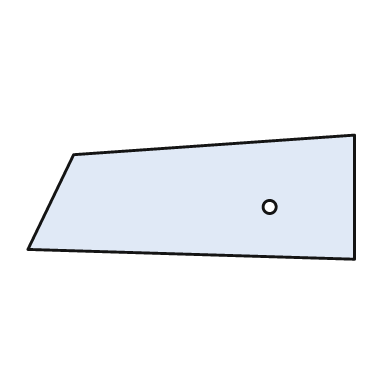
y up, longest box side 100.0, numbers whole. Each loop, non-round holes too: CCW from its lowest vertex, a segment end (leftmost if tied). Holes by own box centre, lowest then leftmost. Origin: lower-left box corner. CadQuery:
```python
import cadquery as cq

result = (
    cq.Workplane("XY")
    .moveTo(100.0, 0.0)
    .lineTo(100.0, 38.0)
    .lineTo(14.0, 32.0)
    .lineTo(0.0, 3.0)
    .close()
    .moveTo(74.0, 16.0)
    .circle(2.0)
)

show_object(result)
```